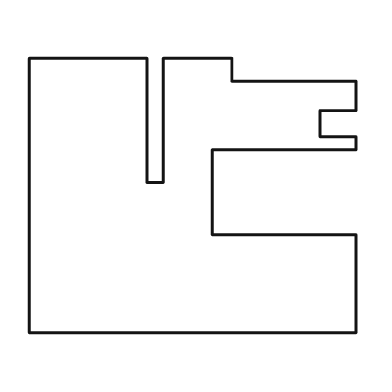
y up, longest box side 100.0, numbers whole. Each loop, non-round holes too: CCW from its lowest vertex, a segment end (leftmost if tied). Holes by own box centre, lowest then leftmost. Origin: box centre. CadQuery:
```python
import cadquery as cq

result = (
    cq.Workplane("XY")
    .moveTo(-50.0, -42.0)
    .lineTo(50.0, -42.0)
    .lineTo(50.0, -12.0)
    .lineTo(6.0, -12.0)
    .lineTo(6.0, 14.0)
    .lineTo(50.0, 14.0)
    .lineTo(50.0, 18.0)
    .lineTo(39.0, 18.0)
    .lineTo(39.0, 26.0)
    .lineTo(50.0, 26.0)
    .lineTo(50.0, 35.0)
    .lineTo(12.0, 35.0)
    .lineTo(12.0, 42.0)
    .lineTo(-9.0, 42.0)
    .lineTo(-9.0, 4.0)
    .lineTo(-14.0, 4.0)
    .lineTo(-14.0, 42.0)
    .lineTo(-50.0, 42.0)
    .close()
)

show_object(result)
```